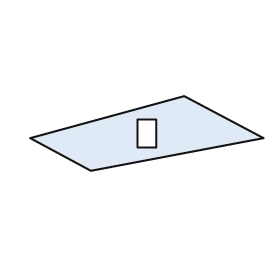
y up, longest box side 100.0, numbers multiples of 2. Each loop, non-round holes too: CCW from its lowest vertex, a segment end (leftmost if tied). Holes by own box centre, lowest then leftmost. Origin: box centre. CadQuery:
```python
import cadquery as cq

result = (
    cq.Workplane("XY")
    .moveTo(-24.0, -16.0)
    .lineTo(50.0, -2.0)
    .lineTo(16.0, 16.0)
    .lineTo(-50.0, -2.0)
    .close()
    .moveTo(-4.0, -6.0)
    .lineTo(4.0, -6.0)
    .lineTo(4.0, 6.0)
    .lineTo(-4.0, 6.0)
    .close()
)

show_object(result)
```